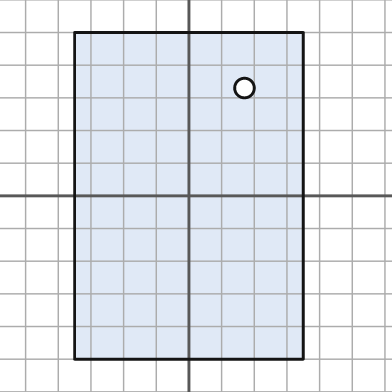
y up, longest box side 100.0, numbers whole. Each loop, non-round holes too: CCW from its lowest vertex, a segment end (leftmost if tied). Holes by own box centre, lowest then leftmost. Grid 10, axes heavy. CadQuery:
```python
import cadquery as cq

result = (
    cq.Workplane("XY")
    .moveTo(-35.0, -50.0)
    .lineTo(35.0, -50.0)
    .lineTo(35.0, 50.0)
    .lineTo(-35.0, 50.0)
    .close()
    .moveTo(17.0, 33.0)
    .circle(3.0)
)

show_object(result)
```